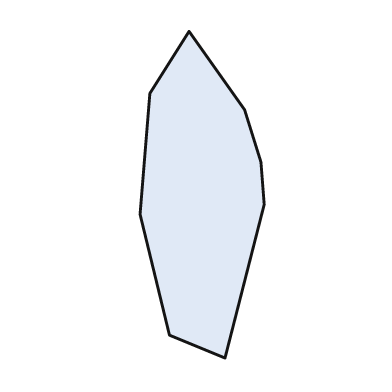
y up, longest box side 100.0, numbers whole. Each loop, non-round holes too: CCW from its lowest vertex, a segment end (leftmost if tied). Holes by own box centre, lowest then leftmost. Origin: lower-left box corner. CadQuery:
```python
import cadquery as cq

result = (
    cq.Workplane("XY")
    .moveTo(26.0, 0.0)
    .lineTo(38.0, 47.0)
    .lineTo(37.0, 60.0)
    .lineTo(32.0, 76.0)
    .lineTo(15.0, 100.0)
    .lineTo(3.0, 81.0)
    .lineTo(0.0, 44.0)
    .lineTo(9.0, 7.0)
    .close()
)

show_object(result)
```